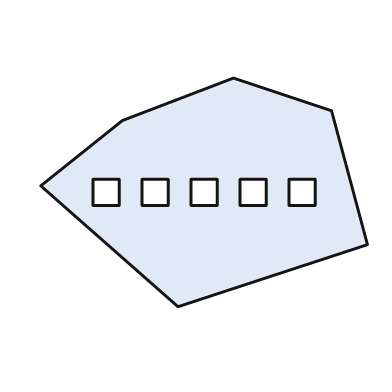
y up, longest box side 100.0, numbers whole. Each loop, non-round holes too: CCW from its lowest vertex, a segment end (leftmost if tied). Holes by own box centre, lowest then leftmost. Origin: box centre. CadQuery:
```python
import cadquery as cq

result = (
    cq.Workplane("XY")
    .moveTo(-8.0, -35.0)
    .lineTo(50.0, -16.0)
    .lineTo(39.0, 25.0)
    .lineTo(9.0, 35.0)
    .lineTo(-25.0, 22.0)
    .lineTo(-50.0, 2.0)
    .close()
    .moveTo(-34.0, -4.0)
    .lineTo(-26.0, -4.0)
    .lineTo(-26.0, 4.0)
    .lineTo(-34.0, 4.0)
    .close()
    .moveTo(-19.0, -4.0)
    .lineTo(-11.0, -4.0)
    .lineTo(-11.0, 4.0)
    .lineTo(-19.0, 4.0)
    .close()
    .moveTo(-4.0, -4.0)
    .lineTo(4.0, -4.0)
    .lineTo(4.0, 4.0)
    .lineTo(-4.0, 4.0)
    .close()
    .moveTo(11.0, -4.0)
    .lineTo(19.0, -4.0)
    .lineTo(19.0, 4.0)
    .lineTo(11.0, 4.0)
    .close()
    .moveTo(26.0, -4.0)
    .lineTo(34.0, -4.0)
    .lineTo(34.0, 4.0)
    .lineTo(26.0, 4.0)
    .close()
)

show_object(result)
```